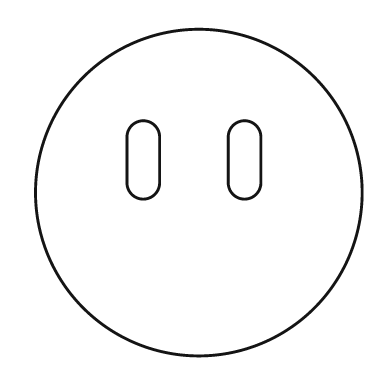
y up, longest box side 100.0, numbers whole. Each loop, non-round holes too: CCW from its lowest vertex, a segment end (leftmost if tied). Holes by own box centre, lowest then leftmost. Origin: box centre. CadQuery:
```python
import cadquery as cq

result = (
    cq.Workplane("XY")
    .moveTo(0.0, 0.0)
    .circle(50.0)
    .moveTo(-22.0, 3.0)
    .threePointArc((-17.0, -2.0), (-12.0, 3.0))
    .lineTo(-12.0, 17.0)
    .threePointArc((-17.0, 22.0), (-22.0, 17.0))
    .close()
    .moveTo(9.0, 3.0)
    .threePointArc((14.0, -2.0), (19.0, 3.0))
    .lineTo(19.0, 17.0)
    .threePointArc((14.0, 22.0), (9.0, 17.0))
    .close()
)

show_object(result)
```